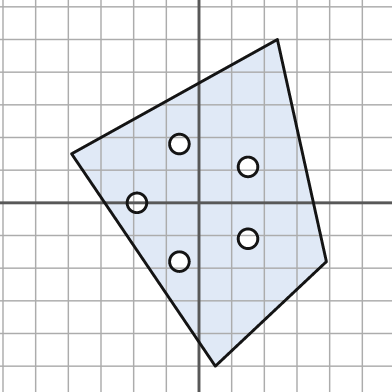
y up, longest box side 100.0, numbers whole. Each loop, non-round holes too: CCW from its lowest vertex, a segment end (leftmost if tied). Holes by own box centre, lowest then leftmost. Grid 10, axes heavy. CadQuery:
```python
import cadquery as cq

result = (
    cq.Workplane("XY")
    .moveTo(5.0, -50.0)
    .lineTo(39.0, -18.0)
    .lineTo(24.0, 50.0)
    .lineTo(-39.0, 15.0)
    .close()
    .moveTo(-6.0, -18.0)
    .circle(3.0)
    .moveTo(15.0, -11.0)
    .circle(3.0)
    .moveTo(-19.0, 0.0)
    .circle(3.0)
    .moveTo(15.0, 11.0)
    .circle(3.0)
    .moveTo(-6.0, 18.0)
    .circle(3.0)
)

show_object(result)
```